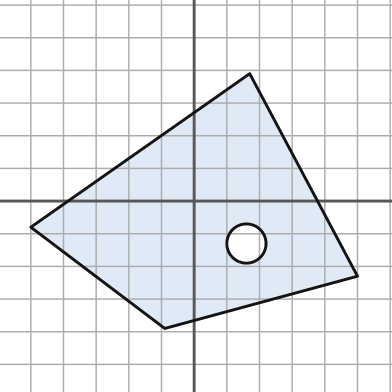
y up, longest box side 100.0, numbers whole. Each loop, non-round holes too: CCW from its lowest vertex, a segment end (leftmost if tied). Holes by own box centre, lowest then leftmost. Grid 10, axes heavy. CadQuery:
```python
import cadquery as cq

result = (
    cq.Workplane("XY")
    .moveTo(-9.0, -39.0)
    .lineTo(50.0, -23.0)
    .lineTo(17.0, 39.0)
    .lineTo(-50.0, -8.0)
    .close()
    .moveTo(16.0, -13.0)
    .circle(6.0)
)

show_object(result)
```